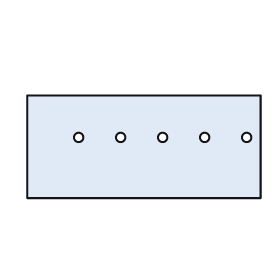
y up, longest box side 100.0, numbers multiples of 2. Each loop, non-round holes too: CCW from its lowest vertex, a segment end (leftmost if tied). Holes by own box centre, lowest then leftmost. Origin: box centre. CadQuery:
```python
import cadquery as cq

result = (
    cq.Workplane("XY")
    .moveTo(-50.0, -22.0)
    .lineTo(50.0, -22.0)
    .lineTo(50.0, 22.0)
    .lineTo(-50.0, 22.0)
    .close()
    .moveTo(-28.0, 4.0)
    .circle(2.0)
    .moveTo(-10.0, 4.0)
    .circle(2.0)
    .moveTo(8.0, 4.0)
    .circle(2.0)
    .moveTo(26.0, 4.0)
    .circle(2.0)
    .moveTo(44.0, 4.0)
    .circle(2.0)
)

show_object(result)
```